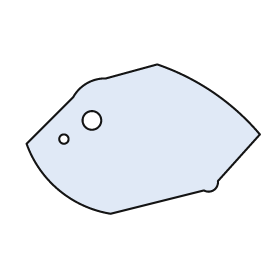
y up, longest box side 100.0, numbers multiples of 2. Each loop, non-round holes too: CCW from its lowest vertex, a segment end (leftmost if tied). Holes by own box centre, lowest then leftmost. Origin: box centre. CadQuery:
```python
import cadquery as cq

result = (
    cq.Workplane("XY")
    .moveTo(-14.0, -32.0)
    .lineTo(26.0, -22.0)
    .threePointArc((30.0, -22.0), (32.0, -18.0))
    .lineTo(50.0, 2.0)
    .threePointArc((30.0, 20.0), (6.0, 32.0))
    .lineTo(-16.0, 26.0)
    .threePointArc((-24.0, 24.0), (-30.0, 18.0))
    .lineTo(-50.0, -2.0)
    .threePointArc((-36.0, -22.0), (-14.0, -32.0))
    .close()
    .moveTo(-34.0, 0.0)
    .circle(2.0)
    .moveTo(-22.0, 8.0)
    .circle(4.0)
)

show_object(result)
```